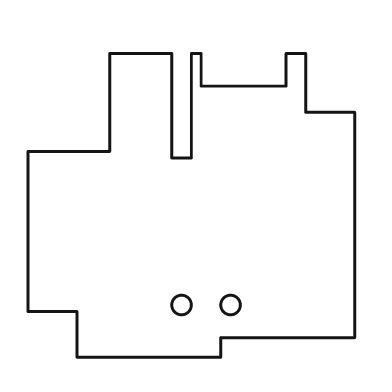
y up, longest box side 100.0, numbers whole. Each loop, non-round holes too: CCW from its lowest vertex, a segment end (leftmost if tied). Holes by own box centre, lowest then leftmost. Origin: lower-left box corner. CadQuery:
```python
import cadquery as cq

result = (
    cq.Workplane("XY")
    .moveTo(15.0, 0.0)
    .lineTo(59.0, 0.0)
    .lineTo(59.0, 6.0)
    .lineTo(100.0, 6.0)
    .lineTo(100.0, 75.0)
    .lineTo(85.0, 75.0)
    .lineTo(85.0, 93.0)
    .lineTo(79.0, 93.0)
    .lineTo(79.0, 83.0)
    .lineTo(53.0, 83.0)
    .lineTo(53.0, 93.0)
    .lineTo(50.0, 93.0)
    .lineTo(50.0, 61.0)
    .lineTo(44.0, 61.0)
    .lineTo(44.0, 93.0)
    .lineTo(25.0, 93.0)
    .lineTo(25.0, 63.0)
    .lineTo(0.0, 63.0)
    .lineTo(0.0, 14.0)
    .lineTo(15.0, 14.0)
    .close()
    .moveTo(47.0, 16.0)
    .circle(3.0)
    .moveTo(62.0, 16.0)
    .circle(3.0)
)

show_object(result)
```